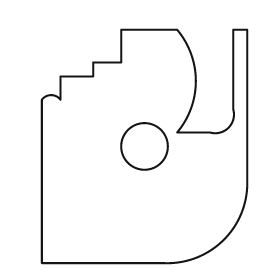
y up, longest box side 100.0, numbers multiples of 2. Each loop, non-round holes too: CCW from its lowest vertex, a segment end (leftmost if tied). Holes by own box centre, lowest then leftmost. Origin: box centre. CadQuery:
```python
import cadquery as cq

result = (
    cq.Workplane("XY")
    .moveTo(-44.0, -50.0)
    .lineTo(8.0, -50.0)
    .threePointArc((34.0, -40.0), (44.0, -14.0))
    .lineTo(44.0, 50.0)
    .lineTo(38.0, 50.0)
    .lineTo(38.0, 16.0)
    .threePointArc((36.0, 8.0), (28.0, 6.0))
    .lineTo(14.0, 6.0)
    .threePointArc((22.0, 28.0), (14.0, 50.0))
    .lineTo(-10.0, 50.0)
    .lineTo(-10.0, 36.0)
    .lineTo(-22.0, 36.0)
    .lineTo(-22.0, 30.0)
    .lineTo(-36.0, 30.0)
    .lineTo(-36.0, 20.0)
    .threePointArc((-40.0, 22.0), (-44.0, 20.0))
    .close()
    .moveTo(0.0, 0.0)
    .circle(10.0)
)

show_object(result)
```